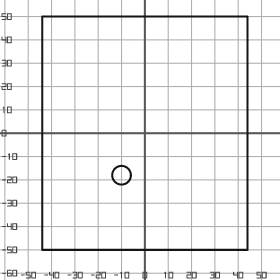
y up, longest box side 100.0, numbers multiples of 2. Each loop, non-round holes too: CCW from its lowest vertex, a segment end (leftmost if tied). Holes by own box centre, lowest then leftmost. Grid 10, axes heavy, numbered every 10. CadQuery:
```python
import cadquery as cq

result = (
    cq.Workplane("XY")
    .moveTo(-44.0, -50.0)
    .lineTo(44.0, -50.0)
    .lineTo(44.0, 50.0)
    .lineTo(-44.0, 50.0)
    .close()
    .moveTo(-10.0, -18.0)
    .circle(4.0)
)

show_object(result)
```